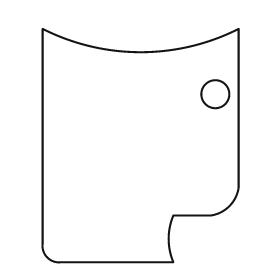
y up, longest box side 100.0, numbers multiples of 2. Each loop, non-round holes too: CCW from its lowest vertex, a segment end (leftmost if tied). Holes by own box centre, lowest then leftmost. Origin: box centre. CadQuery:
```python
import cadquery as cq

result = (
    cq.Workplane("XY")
    .moveTo(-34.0, -50.0)
    .lineTo(14.0, -50.0)
    .threePointArc((12.0, -40.0), (14.0, -30.0))
    .lineTo(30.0, -30.0)
    .threePointArc((38.0, -26.0), (42.0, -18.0))
    .lineTo(42.0, 50.0)
    .threePointArc((0.0, 40.0), (-42.0, 50.0))
    .lineTo(-42.0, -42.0)
    .threePointArc((-40.0, -48.0), (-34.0, -50.0))
    .close()
    .moveTo(32.0, 22.0)
    .circle(6.0)
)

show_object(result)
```